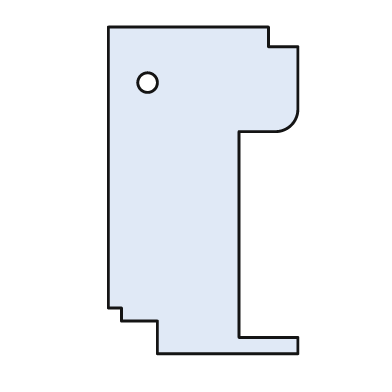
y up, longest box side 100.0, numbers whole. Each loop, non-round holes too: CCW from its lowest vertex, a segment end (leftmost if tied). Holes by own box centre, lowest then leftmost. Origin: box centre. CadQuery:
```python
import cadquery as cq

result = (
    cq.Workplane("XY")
    .moveTo(-14.0, -50.0)
    .lineTo(29.0, -50.0)
    .lineTo(29.0, -45.0)
    .lineTo(11.0, -45.0)
    .lineTo(11.0, 18.0)
    .lineTo(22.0, 18.0)
    .threePointArc((27.0, 20.0), (29.0, 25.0))
    .lineTo(29.0, 44.0)
    .lineTo(20.0, 44.0)
    .lineTo(20.0, 50.0)
    .lineTo(-29.0, 50.0)
    .lineTo(-29.0, -36.0)
    .lineTo(-25.0, -36.0)
    .lineTo(-25.0, -40.0)
    .lineTo(-14.0, -40.0)
    .close()
    .moveTo(-17.0, 33.0)
    .circle(3.0)
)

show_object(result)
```